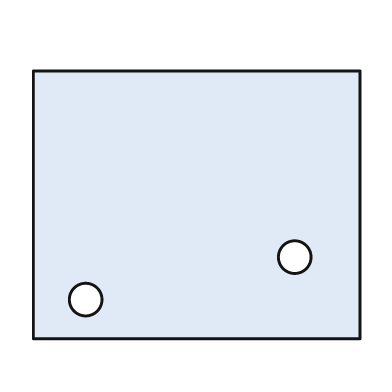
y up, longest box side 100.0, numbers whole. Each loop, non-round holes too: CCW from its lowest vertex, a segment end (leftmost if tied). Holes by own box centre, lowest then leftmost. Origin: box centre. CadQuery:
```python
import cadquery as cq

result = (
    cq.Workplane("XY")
    .moveTo(-50.0, -41.0)
    .lineTo(50.0, -41.0)
    .lineTo(50.0, 41.0)
    .lineTo(-50.0, 41.0)
    .close()
    .moveTo(-34.0, -29.0)
    .circle(5.0)
    .moveTo(30.0, -16.0)
    .circle(5.0)
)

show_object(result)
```